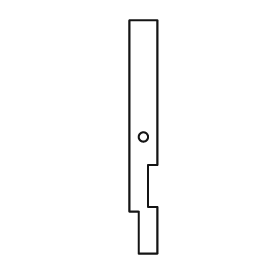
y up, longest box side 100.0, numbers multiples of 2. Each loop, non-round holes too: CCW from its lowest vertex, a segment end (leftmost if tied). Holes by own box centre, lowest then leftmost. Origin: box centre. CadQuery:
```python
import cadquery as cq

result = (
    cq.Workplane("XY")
    .moveTo(-2.0, -50.0)
    .lineTo(6.0, -50.0)
    .lineTo(6.0, -30.0)
    .lineTo(2.0, -30.0)
    .lineTo(2.0, -12.0)
    .lineTo(6.0, -12.0)
    .lineTo(6.0, 50.0)
    .lineTo(-6.0, 50.0)
    .lineTo(-6.0, -32.0)
    .lineTo(-2.0, -32.0)
    .close()
    .moveTo(0.0, 0.0)
    .circle(2.0)
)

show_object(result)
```